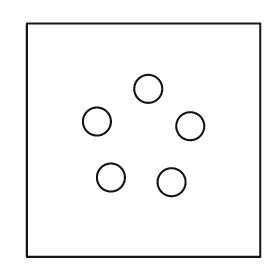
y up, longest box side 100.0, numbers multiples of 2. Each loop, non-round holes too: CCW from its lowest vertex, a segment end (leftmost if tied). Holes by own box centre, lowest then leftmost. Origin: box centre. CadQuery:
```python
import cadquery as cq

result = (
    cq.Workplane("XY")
    .moveTo(-50.0, -50.0)
    .lineTo(50.0, -50.0)
    .lineTo(50.0, 50.0)
    .lineTo(-50.0, 50.0)
    .close()
    .moveTo(12.0, -18.0)
    .circle(6.0)
    .moveTo(-14.0, -16.0)
    .circle(6.0)
    .moveTo(20.0, 6.0)
    .circle(6.0)
    .moveTo(-20.0, 8.0)
    .circle(6.0)
    .moveTo(2.0, 22.0)
    .circle(6.0)
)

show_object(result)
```